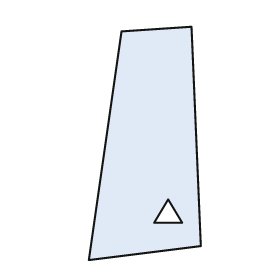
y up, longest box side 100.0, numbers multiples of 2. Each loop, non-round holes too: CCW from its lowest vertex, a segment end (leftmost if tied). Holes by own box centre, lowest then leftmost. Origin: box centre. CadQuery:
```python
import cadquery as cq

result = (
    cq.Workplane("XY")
    .moveTo(-24.0, -50.0)
    .lineTo(24.0, -44.0)
    .lineTo(20.0, 50.0)
    .lineTo(-10.0, 48.0)
    .close()
    .moveTo(4.0, -34.0)
    .lineTo(16.0, -34.0)
    .lineTo(10.0, -24.0)
    .close()
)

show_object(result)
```